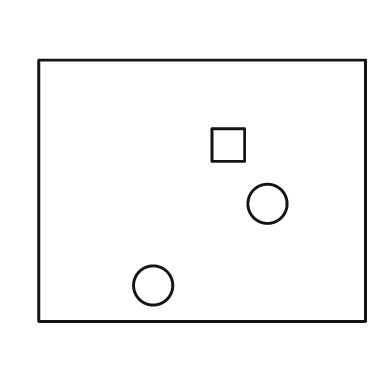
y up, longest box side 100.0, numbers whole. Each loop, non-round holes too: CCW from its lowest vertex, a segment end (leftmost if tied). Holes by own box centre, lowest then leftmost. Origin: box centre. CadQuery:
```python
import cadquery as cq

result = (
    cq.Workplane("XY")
    .moveTo(-50.0, -40.0)
    .lineTo(50.0, -40.0)
    .lineTo(50.0, 40.0)
    .lineTo(-50.0, 40.0)
    .close()
    .moveTo(-15.0, -29.0)
    .circle(6.0)
    .moveTo(20.0, -4.0)
    .circle(6.0)
    .moveTo(3.0, 9.0)
    .lineTo(13.0, 9.0)
    .lineTo(13.0, 19.0)
    .lineTo(3.0, 19.0)
    .close()
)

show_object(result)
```